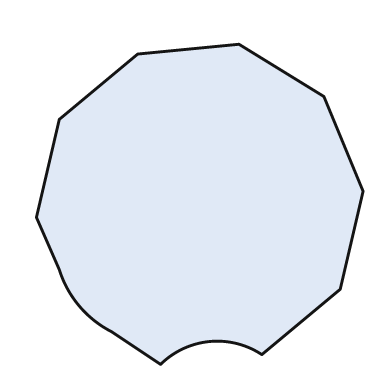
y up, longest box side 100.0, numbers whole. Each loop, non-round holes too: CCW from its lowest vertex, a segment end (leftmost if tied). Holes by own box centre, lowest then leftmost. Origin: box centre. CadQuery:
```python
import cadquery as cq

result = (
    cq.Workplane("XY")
    .moveTo(-12.0, -49.0)
    .threePointArc((3.0, -42.0), (19.0, -46.0))
    .lineTo(43.0, -26.0)
    .lineTo(50.0, 4.0)
    .lineTo(38.0, 33.0)
    .lineTo(12.0, 49.0)
    .lineTo(-19.0, 46.0)
    .lineTo(-43.0, 26.0)
    .lineTo(-50.0, -4.0)
    .lineTo(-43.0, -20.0)
    .threePointArc((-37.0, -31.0), (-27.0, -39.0))
    .close()
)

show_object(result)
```